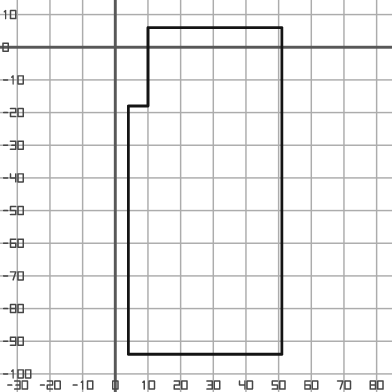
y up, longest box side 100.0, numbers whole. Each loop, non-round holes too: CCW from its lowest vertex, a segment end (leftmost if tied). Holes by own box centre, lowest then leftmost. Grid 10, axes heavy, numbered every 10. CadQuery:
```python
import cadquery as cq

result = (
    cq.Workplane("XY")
    .moveTo(4.0, -94.0)
    .lineTo(51.0, -94.0)
    .lineTo(51.0, 6.0)
    .lineTo(10.0, 6.0)
    .lineTo(10.0, -18.0)
    .lineTo(4.0, -18.0)
    .close()
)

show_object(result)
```